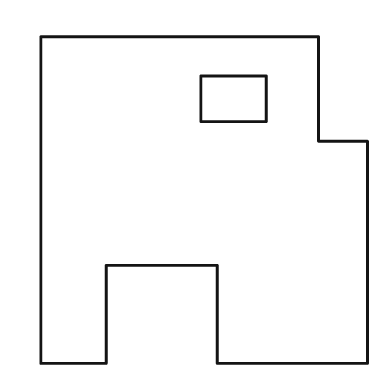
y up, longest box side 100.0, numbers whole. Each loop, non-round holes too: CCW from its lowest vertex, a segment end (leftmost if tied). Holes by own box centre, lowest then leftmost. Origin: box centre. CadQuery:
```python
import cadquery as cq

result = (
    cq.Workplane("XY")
    .moveTo(-50.0, -50.0)
    .lineTo(-30.0, -50.0)
    .lineTo(-30.0, -20.0)
    .lineTo(4.0, -20.0)
    .lineTo(4.0, -50.0)
    .lineTo(50.0, -50.0)
    .lineTo(50.0, 18.0)
    .lineTo(35.0, 18.0)
    .lineTo(35.0, 50.0)
    .lineTo(-50.0, 50.0)
    .close()
    .moveTo(-1.0, 24.0)
    .lineTo(19.0, 24.0)
    .lineTo(19.0, 38.0)
    .lineTo(-1.0, 38.0)
    .close()
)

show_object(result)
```